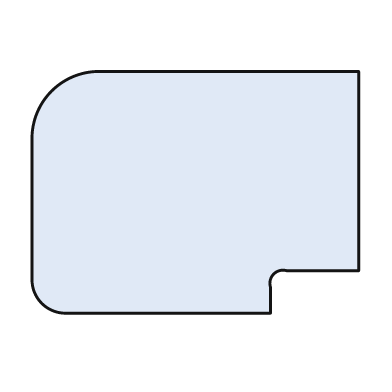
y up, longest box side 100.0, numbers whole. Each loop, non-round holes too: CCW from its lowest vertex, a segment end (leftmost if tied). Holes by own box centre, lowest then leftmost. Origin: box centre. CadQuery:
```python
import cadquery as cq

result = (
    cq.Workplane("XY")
    .moveTo(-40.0, -37.0)
    .lineTo(23.0, -37.0)
    .lineTo(23.0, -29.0)
    .threePointArc((24.0, -25.0), (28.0, -24.0))
    .lineTo(50.0, -24.0)
    .lineTo(50.0, 37.0)
    .lineTo(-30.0, 37.0)
    .threePointArc((-44.0, 31.0), (-50.0, 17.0))
    .lineTo(-50.0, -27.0)
    .threePointArc((-47.0, -34.0), (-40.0, -37.0))
    .close()
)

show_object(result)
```